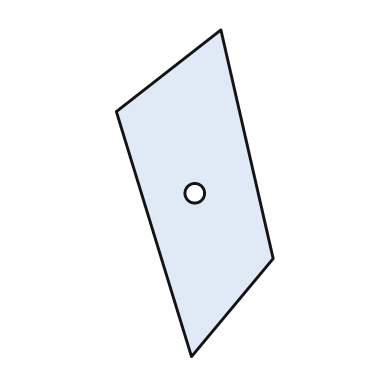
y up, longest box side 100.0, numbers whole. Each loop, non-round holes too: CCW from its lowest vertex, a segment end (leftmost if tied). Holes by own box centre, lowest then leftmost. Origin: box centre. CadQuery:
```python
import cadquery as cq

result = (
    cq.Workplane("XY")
    .moveTo(-1.0, -50.0)
    .lineTo(24.0, -20.0)
    .lineTo(8.0, 50.0)
    .lineTo(-24.0, 25.0)
    .close()
    .moveTo(0.0, 0.0)
    .circle(3.0)
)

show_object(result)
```